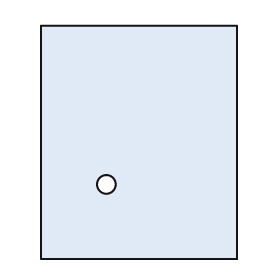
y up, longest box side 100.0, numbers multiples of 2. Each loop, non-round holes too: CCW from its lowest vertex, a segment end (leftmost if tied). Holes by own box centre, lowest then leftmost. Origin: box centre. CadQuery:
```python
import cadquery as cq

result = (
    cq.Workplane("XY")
    .moveTo(-42.0, -50.0)
    .lineTo(42.0, -50.0)
    .lineTo(42.0, 50.0)
    .lineTo(-42.0, 50.0)
    .close()
    .moveTo(-14.0, -18.0)
    .circle(4.0)
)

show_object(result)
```